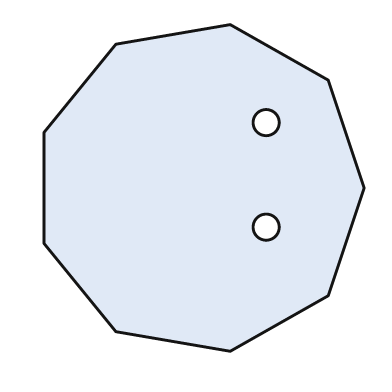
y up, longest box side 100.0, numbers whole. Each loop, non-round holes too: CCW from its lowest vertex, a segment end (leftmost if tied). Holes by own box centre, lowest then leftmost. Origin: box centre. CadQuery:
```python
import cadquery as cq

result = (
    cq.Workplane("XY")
    .moveTo(8.0, -50.0)
    .lineTo(38.0, -33.0)
    .lineTo(49.0, 0.0)
    .lineTo(38.0, 33.0)
    .lineTo(8.0, 50.0)
    .lineTo(-27.0, 44.0)
    .lineTo(-49.0, 17.0)
    .lineTo(-49.0, -17.0)
    .lineTo(-27.0, -44.0)
    .close()
    .moveTo(19.0, -12.0)
    .circle(4.0)
    .moveTo(19.0, 20.0)
    .circle(4.0)
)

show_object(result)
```